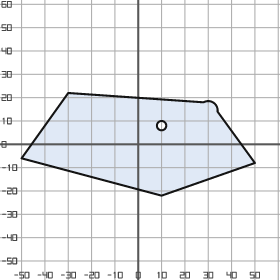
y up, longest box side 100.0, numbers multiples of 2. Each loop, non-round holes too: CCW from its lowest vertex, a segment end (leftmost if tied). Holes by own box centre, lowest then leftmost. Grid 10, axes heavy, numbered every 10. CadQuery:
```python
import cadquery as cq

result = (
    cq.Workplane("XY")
    .moveTo(10.0, -22.0)
    .lineTo(50.0, -8.0)
    .lineTo(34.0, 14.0)
    .threePointArc((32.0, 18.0), (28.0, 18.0))
    .lineTo(-30.0, 22.0)
    .lineTo(-50.0, -6.0)
    .close()
    .moveTo(10.0, 8.0)
    .circle(2.0)
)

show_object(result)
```